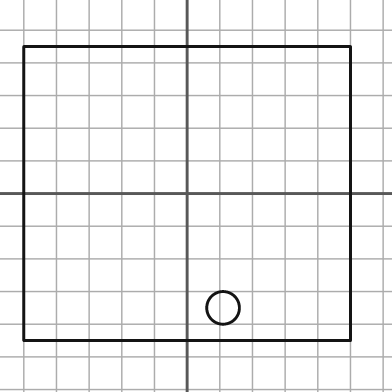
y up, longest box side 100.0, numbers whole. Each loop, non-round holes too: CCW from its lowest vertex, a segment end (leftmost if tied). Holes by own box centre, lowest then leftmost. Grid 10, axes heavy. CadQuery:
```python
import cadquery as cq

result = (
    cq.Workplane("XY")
    .moveTo(-50.0, -45.0)
    .lineTo(50.0, -45.0)
    .lineTo(50.0, 45.0)
    .lineTo(-50.0, 45.0)
    .close()
    .moveTo(11.0, -35.0)
    .circle(5.0)
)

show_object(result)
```